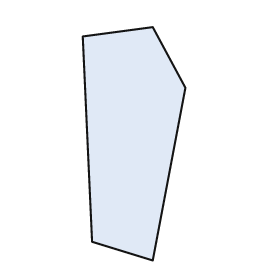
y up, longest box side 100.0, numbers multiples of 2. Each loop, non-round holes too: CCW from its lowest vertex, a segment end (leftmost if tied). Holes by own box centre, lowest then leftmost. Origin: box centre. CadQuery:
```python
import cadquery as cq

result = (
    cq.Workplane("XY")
    .moveTo(8.0, -50.0)
    .lineTo(22.0, 24.0)
    .lineTo(8.0, 50.0)
    .lineTo(-22.0, 46.0)
    .lineTo(-18.0, -42.0)
    .close()
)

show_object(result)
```